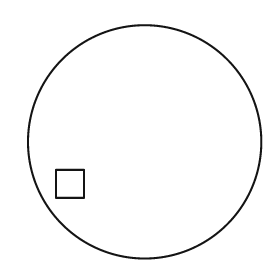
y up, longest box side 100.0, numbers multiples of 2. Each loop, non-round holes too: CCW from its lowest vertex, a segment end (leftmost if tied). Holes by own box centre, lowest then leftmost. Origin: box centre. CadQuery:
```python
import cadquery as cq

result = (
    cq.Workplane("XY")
    .moveTo(0.0, 0.0)
    .circle(50.0)
    .moveTo(-38.0, -24.0)
    .lineTo(-26.0, -24.0)
    .lineTo(-26.0, -12.0)
    .lineTo(-38.0, -12.0)
    .close()
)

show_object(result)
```